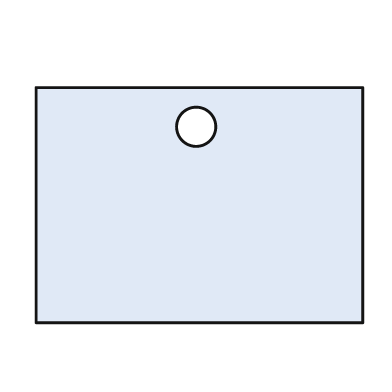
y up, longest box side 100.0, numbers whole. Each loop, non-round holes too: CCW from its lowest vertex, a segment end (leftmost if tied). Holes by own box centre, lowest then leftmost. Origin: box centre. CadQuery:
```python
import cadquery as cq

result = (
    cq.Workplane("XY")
    .moveTo(-50.0, -36.0)
    .lineTo(50.0, -36.0)
    .lineTo(50.0, 36.0)
    .lineTo(-50.0, 36.0)
    .close()
    .moveTo(-1.0, 24.0)
    .circle(6.0)
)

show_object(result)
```